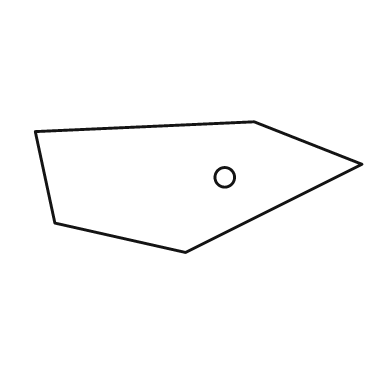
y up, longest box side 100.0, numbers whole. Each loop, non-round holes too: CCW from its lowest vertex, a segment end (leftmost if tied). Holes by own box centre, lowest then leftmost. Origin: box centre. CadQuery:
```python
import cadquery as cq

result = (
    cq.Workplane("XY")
    .moveTo(-4.0, -20.0)
    .lineTo(50.0, 7.0)
    .lineTo(17.0, 20.0)
    .lineTo(-50.0, 17.0)
    .lineTo(-44.0, -11.0)
    .close()
    .moveTo(8.0, 3.0)
    .circle(3.0)
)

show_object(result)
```